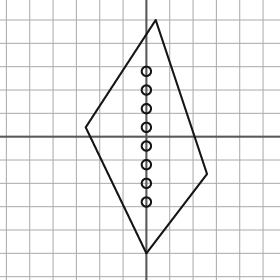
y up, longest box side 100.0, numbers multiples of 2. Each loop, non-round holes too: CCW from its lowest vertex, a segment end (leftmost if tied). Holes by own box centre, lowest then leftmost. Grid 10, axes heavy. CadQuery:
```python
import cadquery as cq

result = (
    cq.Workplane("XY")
    .moveTo(0.0, -50.0)
    .lineTo(26.0, -16.0)
    .lineTo(4.0, 50.0)
    .lineTo(-26.0, 4.0)
    .close()
    .moveTo(0.0, -28.0)
    .circle(2.0)
    .moveTo(0.0, -20.0)
    .circle(2.0)
    .moveTo(0.0, -12.0)
    .circle(2.0)
    .moveTo(0.0, -4.0)
    .circle(2.0)
    .moveTo(0.0, 4.0)
    .circle(2.0)
    .moveTo(0.0, 12.0)
    .circle(2.0)
    .moveTo(0.0, 20.0)
    .circle(2.0)
    .moveTo(0.0, 28.0)
    .circle(2.0)
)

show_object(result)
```